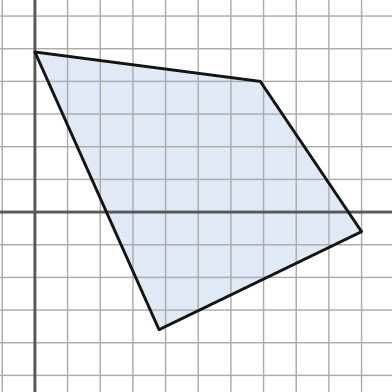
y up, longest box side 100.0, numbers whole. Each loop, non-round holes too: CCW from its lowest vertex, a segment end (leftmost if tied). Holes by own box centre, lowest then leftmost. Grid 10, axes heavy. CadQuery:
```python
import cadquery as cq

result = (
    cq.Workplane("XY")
    .moveTo(38.0, -36.0)
    .lineTo(100.0, -6.0)
    .lineTo(69.0, 40.0)
    .lineTo(0.0, 49.0)
    .close()
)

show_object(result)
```